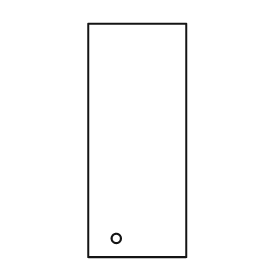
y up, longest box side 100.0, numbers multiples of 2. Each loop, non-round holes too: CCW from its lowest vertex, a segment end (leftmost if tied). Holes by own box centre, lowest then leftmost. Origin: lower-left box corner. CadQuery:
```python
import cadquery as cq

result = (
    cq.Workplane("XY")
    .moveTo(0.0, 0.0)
    .lineTo(42.0, 0.0)
    .lineTo(42.0, 100.0)
    .lineTo(0.0, 100.0)
    .close()
    .moveTo(12.0, 8.0)
    .circle(2.0)
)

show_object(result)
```